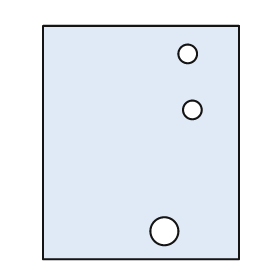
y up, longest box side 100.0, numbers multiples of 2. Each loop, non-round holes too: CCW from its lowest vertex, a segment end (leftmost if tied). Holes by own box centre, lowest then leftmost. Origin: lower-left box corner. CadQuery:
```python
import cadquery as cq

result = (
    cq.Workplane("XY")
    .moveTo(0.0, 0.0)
    .lineTo(84.0, 0.0)
    .lineTo(84.0, 100.0)
    .lineTo(0.0, 100.0)
    .close()
    .moveTo(52.0, 12.0)
    .circle(6.0)
    .moveTo(64.0, 64.0)
    .circle(4.0)
    .moveTo(62.0, 88.0)
    .circle(4.0)
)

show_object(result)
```